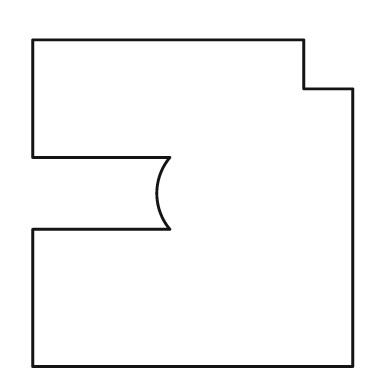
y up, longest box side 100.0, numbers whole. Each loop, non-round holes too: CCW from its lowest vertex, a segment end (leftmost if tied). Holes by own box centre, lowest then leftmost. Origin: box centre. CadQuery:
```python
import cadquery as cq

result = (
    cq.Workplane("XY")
    .moveTo(-49.0, -50.0)
    .lineTo(49.0, -50.0)
    .lineTo(49.0, 35.0)
    .lineTo(34.0, 35.0)
    .lineTo(34.0, 50.0)
    .lineTo(-49.0, 50.0)
    .lineTo(-49.0, 14.0)
    .lineTo(-7.0, 14.0)
    .threePointArc((-11.0, 3.0), (-7.0, -8.0))
    .lineTo(-49.0, -8.0)
    .close()
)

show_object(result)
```